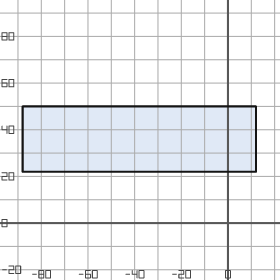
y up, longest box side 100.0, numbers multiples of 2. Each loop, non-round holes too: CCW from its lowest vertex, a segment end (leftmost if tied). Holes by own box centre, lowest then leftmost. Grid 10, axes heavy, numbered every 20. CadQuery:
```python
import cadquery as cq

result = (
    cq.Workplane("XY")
    .moveTo(-88.0, 22.0)
    .lineTo(12.0, 22.0)
    .lineTo(12.0, 50.0)
    .lineTo(-88.0, 50.0)
    .close()
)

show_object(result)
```